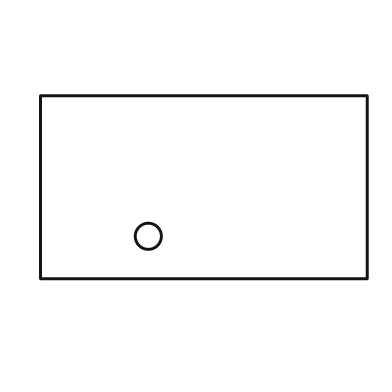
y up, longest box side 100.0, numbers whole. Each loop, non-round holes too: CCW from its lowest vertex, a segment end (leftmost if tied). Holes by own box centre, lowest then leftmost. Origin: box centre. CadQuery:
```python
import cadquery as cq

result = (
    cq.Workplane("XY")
    .moveTo(-50.0, -28.0)
    .lineTo(50.0, -28.0)
    .lineTo(50.0, 28.0)
    .lineTo(-50.0, 28.0)
    .close()
    .moveTo(-17.0, -15.0)
    .circle(4.0)
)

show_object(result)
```